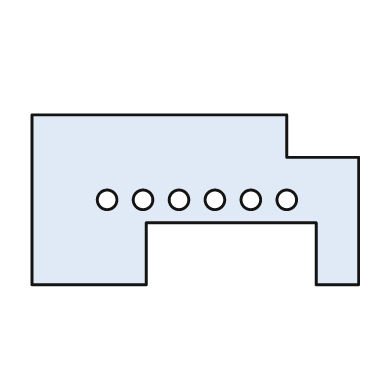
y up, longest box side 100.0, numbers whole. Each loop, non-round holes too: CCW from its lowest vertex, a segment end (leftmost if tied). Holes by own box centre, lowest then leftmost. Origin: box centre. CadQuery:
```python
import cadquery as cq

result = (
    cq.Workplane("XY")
    .moveTo(-50.0, -26.0)
    .lineTo(-15.0, -26.0)
    .lineTo(-15.0, -7.0)
    .lineTo(37.0, -7.0)
    .lineTo(37.0, -26.0)
    .lineTo(50.0, -26.0)
    .lineTo(50.0, 13.0)
    .lineTo(28.0, 13.0)
    .lineTo(28.0, 26.0)
    .lineTo(-50.0, 26.0)
    .close()
    .moveTo(-27.0, 0.0)
    .circle(3.0)
    .moveTo(-16.0, 0.0)
    .circle(3.0)
    .moveTo(-5.0, 0.0)
    .circle(3.0)
    .moveTo(6.0, 0.0)
    .circle(3.0)
    .moveTo(17.0, 0.0)
    .circle(3.0)
    .moveTo(28.0, 0.0)
    .circle(3.0)
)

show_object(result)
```